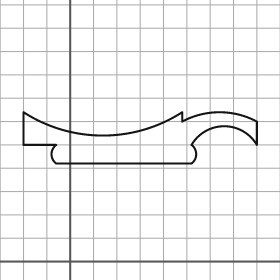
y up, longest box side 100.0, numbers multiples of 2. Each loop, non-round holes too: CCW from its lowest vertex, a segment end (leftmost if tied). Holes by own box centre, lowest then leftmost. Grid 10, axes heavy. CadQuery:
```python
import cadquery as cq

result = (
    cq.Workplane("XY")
    .moveTo(-6.0, 42.0)
    .lineTo(52.0, 42.0)
    .threePointArc((54.0, 46.0), (52.0, 50.0))
    .threePointArc((66.0, 58.0), (80.0, 50.0))
    .lineTo(80.0, 60.0)
    .threePointArc((64.0, 64.0), (48.0, 60.0))
    .lineTo(48.0, 64.0)
    .threePointArc((14.0, 54.0), (-20.0, 64.0))
    .lineTo(-20.0, 50.0)
    .lineTo(-6.0, 50.0)
    .threePointArc((-8.0, 46.0), (-6.0, 42.0))
    .close()
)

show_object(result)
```